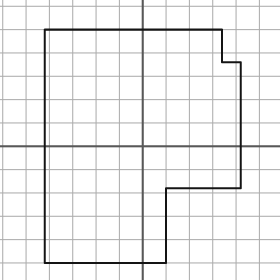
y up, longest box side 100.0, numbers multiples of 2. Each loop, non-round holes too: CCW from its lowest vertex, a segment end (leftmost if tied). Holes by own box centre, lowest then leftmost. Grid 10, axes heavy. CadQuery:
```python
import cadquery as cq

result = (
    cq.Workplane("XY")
    .moveTo(-42.0, -50.0)
    .lineTo(10.0, -50.0)
    .lineTo(10.0, -18.0)
    .lineTo(42.0, -18.0)
    .lineTo(42.0, 36.0)
    .lineTo(34.0, 36.0)
    .lineTo(34.0, 50.0)
    .lineTo(-42.0, 50.0)
    .close()
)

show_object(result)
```